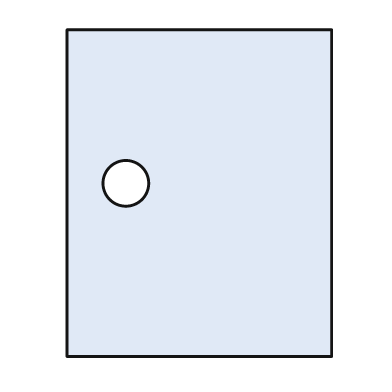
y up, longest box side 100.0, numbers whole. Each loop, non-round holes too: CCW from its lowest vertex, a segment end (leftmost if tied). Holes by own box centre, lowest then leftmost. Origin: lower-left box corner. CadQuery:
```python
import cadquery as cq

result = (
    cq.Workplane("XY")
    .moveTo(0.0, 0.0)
    .lineTo(81.0, 0.0)
    .lineTo(81.0, 100.0)
    .lineTo(0.0, 100.0)
    .close()
    .moveTo(18.0, 53.0)
    .circle(7.0)
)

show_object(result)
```